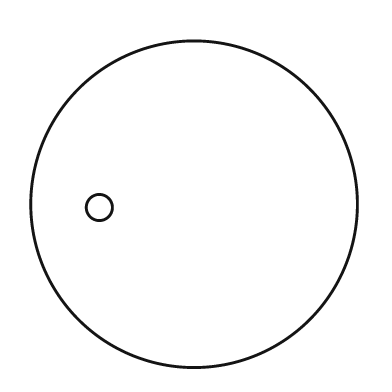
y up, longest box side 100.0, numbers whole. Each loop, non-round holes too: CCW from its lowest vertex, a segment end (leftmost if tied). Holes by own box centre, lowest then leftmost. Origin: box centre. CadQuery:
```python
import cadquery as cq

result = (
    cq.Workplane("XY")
    .moveTo(0.0, 0.0)
    .circle(50.0)
    .moveTo(-29.0, -1.0)
    .circle(4.0)
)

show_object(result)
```